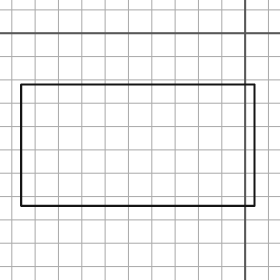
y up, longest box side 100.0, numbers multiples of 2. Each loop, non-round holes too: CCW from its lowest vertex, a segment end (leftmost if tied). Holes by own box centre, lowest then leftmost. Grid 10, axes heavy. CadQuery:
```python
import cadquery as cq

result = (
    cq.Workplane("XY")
    .moveTo(-96.0, -74.0)
    .lineTo(4.0, -74.0)
    .lineTo(4.0, -22.0)
    .lineTo(-96.0, -22.0)
    .close()
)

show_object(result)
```